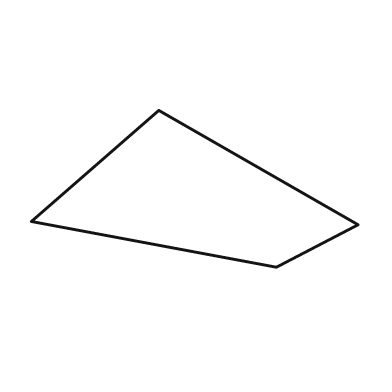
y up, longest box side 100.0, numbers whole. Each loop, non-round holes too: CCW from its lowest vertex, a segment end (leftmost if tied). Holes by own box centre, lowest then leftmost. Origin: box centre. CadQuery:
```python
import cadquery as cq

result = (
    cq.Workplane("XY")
    .moveTo(25.0, -24.0)
    .lineTo(50.0, -11.0)
    .lineTo(-11.0, 24.0)
    .lineTo(-50.0, -10.0)
    .close()
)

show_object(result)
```